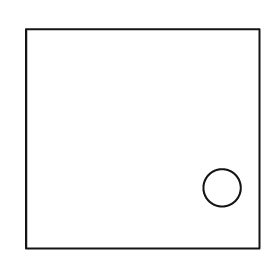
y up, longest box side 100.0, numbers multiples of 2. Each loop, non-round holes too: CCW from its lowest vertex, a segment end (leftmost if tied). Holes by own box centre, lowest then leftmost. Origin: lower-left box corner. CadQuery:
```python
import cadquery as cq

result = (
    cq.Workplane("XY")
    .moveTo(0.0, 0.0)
    .lineTo(100.0, 0.0)
    .lineTo(100.0, 94.0)
    .lineTo(0.0, 94.0)
    .close()
    .moveTo(84.0, 26.0)
    .circle(8.0)
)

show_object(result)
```